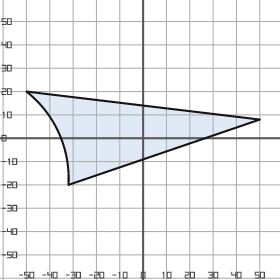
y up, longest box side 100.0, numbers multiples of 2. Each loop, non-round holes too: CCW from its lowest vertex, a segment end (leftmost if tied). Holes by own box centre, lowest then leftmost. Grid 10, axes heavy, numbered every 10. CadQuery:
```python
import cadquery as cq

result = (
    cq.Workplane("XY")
    .moveTo(-32.0, -20.0)
    .lineTo(50.0, 8.0)
    .lineTo(-50.0, 20.0)
    .threePointArc((-36.0, 2.0), (-32.0, -20.0))
    .close()
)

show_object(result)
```